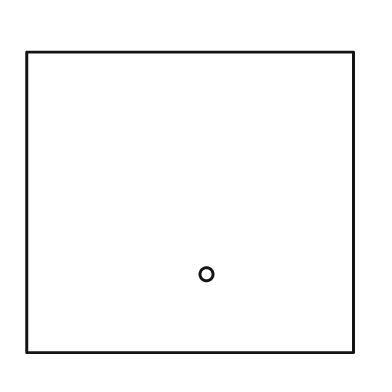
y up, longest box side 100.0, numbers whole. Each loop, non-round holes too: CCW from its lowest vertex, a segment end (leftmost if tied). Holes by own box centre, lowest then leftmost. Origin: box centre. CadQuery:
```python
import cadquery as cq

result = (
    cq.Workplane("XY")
    .moveTo(-50.0, -46.0)
    .lineTo(50.0, -46.0)
    .lineTo(50.0, 46.0)
    .lineTo(-50.0, 46.0)
    .close()
    .moveTo(5.0, -22.0)
    .circle(2.0)
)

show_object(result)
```